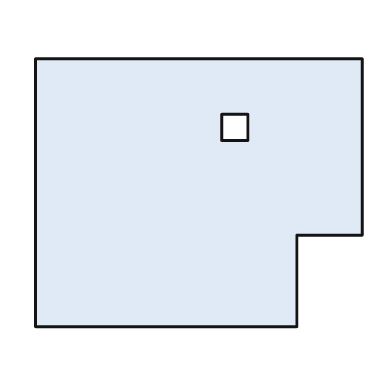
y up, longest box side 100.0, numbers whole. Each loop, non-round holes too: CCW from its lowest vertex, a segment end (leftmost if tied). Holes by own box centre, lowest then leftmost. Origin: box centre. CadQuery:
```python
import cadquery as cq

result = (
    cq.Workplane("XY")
    .moveTo(-50.0, -41.0)
    .lineTo(30.0, -41.0)
    .lineTo(30.0, -13.0)
    .lineTo(50.0, -13.0)
    .lineTo(50.0, 41.0)
    .lineTo(-50.0, 41.0)
    .close()
    .moveTo(7.0, 16.0)
    .lineTo(15.0, 16.0)
    .lineTo(15.0, 24.0)
    .lineTo(7.0, 24.0)
    .close()
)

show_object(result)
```